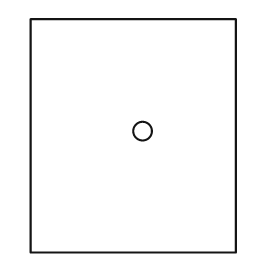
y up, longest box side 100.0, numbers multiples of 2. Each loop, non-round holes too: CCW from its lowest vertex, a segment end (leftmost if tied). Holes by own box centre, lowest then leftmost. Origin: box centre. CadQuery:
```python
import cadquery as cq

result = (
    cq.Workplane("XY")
    .moveTo(-44.0, -50.0)
    .lineTo(44.0, -50.0)
    .lineTo(44.0, 50.0)
    .lineTo(-44.0, 50.0)
    .close()
    .moveTo(4.0, 2.0)
    .circle(4.0)
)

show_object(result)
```